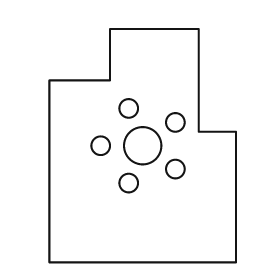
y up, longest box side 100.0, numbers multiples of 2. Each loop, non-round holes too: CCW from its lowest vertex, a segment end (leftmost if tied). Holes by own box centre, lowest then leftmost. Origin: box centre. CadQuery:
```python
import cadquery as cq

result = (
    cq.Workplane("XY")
    .moveTo(-40.0, -50.0)
    .lineTo(40.0, -50.0)
    .lineTo(40.0, 6.0)
    .lineTo(24.0, 6.0)
    .lineTo(24.0, 50.0)
    .lineTo(-14.0, 50.0)
    .lineTo(-14.0, 28.0)
    .lineTo(-40.0, 28.0)
    .close()
    .moveTo(-6.0, -16.0)
    .circle(4.0)
    .moveTo(14.0, -10.0)
    .circle(4.0)
    .moveTo(-18.0, 0.0)
    .circle(4.0)
    .moveTo(0.0, 0.0)
    .circle(8.0)
    .moveTo(14.0, 10.0)
    .circle(4.0)
    .moveTo(-6.0, 16.0)
    .circle(4.0)
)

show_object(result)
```